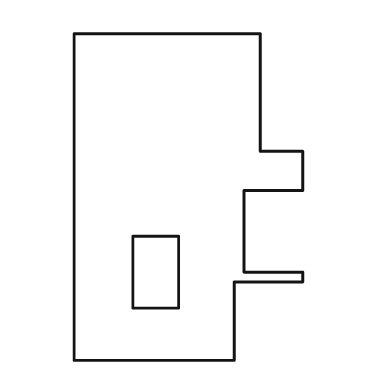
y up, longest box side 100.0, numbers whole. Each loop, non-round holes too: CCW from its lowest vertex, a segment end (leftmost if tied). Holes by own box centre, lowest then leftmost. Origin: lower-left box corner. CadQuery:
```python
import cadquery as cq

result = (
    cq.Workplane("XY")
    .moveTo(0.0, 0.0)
    .lineTo(49.0, 0.0)
    .lineTo(49.0, 24.0)
    .lineTo(70.0, 24.0)
    .lineTo(70.0, 27.0)
    .lineTo(52.0, 27.0)
    .lineTo(52.0, 52.0)
    .lineTo(70.0, 52.0)
    .lineTo(70.0, 64.0)
    .lineTo(57.0, 64.0)
    .lineTo(57.0, 100.0)
    .lineTo(0.0, 100.0)
    .close()
    .moveTo(18.0, 16.0)
    .lineTo(32.0, 16.0)
    .lineTo(32.0, 38.0)
    .lineTo(18.0, 38.0)
    .close()
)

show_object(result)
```